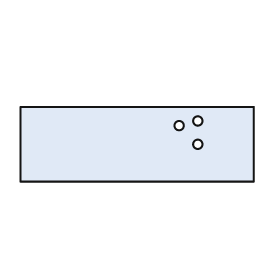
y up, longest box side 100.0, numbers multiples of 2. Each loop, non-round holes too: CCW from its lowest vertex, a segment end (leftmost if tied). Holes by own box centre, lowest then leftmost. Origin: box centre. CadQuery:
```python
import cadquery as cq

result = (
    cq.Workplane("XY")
    .moveTo(-50.0, -16.0)
    .lineTo(50.0, -16.0)
    .lineTo(50.0, 16.0)
    .lineTo(-50.0, 16.0)
    .close()
    .moveTo(26.0, 0.0)
    .circle(2.0)
    .moveTo(18.0, 8.0)
    .circle(2.0)
    .moveTo(26.0, 10.0)
    .circle(2.0)
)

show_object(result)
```